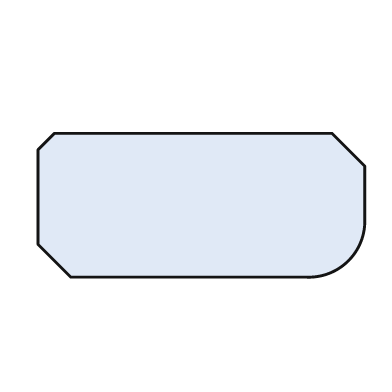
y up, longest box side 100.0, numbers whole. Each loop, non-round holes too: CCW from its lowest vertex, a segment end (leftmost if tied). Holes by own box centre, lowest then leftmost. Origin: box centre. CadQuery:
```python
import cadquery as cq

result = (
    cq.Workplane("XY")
    .moveTo(-40.0, -22.0)
    .lineTo(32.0, -22.0)
    .threePointArc((45.0, -17.0), (50.0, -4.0))
    .lineTo(50.0, 12.0)
    .lineTo(40.0, 22.0)
    .lineTo(-45.0, 22.0)
    .lineTo(-50.0, 17.0)
    .lineTo(-50.0, -12.0)
    .close()
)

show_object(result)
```